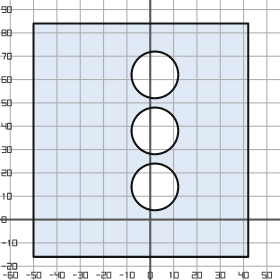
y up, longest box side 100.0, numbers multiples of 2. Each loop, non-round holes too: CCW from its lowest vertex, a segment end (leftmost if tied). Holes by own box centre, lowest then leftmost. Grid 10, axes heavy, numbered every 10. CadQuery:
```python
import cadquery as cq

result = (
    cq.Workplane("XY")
    .moveTo(-50.0, -16.0)
    .lineTo(42.0, -16.0)
    .lineTo(42.0, 84.0)
    .lineTo(-50.0, 84.0)
    .close()
    .moveTo(2.0, 14.0)
    .circle(10.0)
    .moveTo(2.0, 38.0)
    .circle(10.0)
    .moveTo(2.0, 62.0)
    .circle(10.0)
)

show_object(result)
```